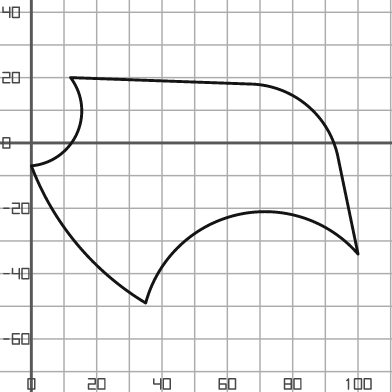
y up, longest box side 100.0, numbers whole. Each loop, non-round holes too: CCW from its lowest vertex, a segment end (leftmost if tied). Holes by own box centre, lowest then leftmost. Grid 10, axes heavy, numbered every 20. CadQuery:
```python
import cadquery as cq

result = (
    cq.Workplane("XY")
    .moveTo(35.0, -49.0)
    .threePointArc((63.0, -22.0), (100.0, -34.0))
    .lineTo(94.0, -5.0)
    .threePointArc((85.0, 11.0), (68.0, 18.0))
    .lineTo(12.0, 20.0)
    .threePointArc((14.0, 3.0), (0.0, -7.0))
    .threePointArc((14.0, -31.0), (35.0, -49.0))
    .close()
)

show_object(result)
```